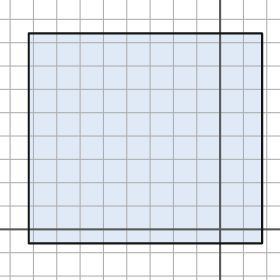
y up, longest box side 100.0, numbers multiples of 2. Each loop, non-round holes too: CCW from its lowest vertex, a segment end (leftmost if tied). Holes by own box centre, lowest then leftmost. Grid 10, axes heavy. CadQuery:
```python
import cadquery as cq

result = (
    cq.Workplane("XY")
    .moveTo(-82.0, -6.0)
    .lineTo(18.0, -6.0)
    .lineTo(18.0, 84.0)
    .lineTo(-82.0, 84.0)
    .close()
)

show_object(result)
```